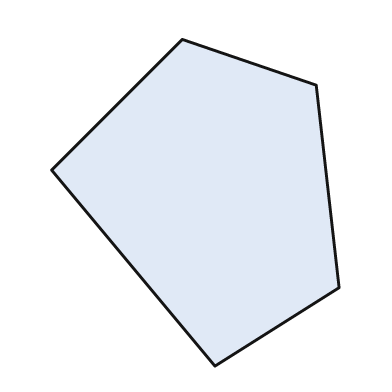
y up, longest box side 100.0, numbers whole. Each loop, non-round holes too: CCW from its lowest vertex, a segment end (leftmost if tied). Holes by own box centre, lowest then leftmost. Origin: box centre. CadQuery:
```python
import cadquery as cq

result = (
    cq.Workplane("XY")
    .moveTo(6.0, -50.0)
    .lineTo(44.0, -26.0)
    .lineTo(37.0, 36.0)
    .lineTo(-4.0, 50.0)
    .lineTo(-44.0, 10.0)
    .close()
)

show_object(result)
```